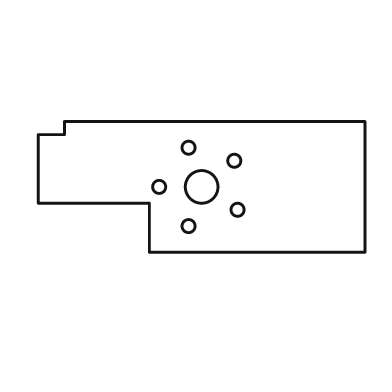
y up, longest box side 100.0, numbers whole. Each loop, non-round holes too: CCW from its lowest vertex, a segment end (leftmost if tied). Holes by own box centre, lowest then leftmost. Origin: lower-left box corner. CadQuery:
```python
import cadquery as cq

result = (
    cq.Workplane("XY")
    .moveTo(34.0, 0.0)
    .lineTo(100.0, 0.0)
    .lineTo(100.0, 40.0)
    .lineTo(8.0, 40.0)
    .lineTo(8.0, 36.0)
    .lineTo(0.0, 36.0)
    .lineTo(0.0, 15.0)
    .lineTo(34.0, 15.0)
    .close()
    .moveTo(46.0, 8.0)
    .circle(2.0)
    .moveTo(61.0, 13.0)
    .circle(2.0)
    .moveTo(37.0, 20.0)
    .circle(2.0)
    .moveTo(50.0, 20.0)
    .circle(5.0)
    .moveTo(60.0, 28.0)
    .circle(2.0)
    .moveTo(46.0, 32.0)
    .circle(2.0)
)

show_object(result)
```